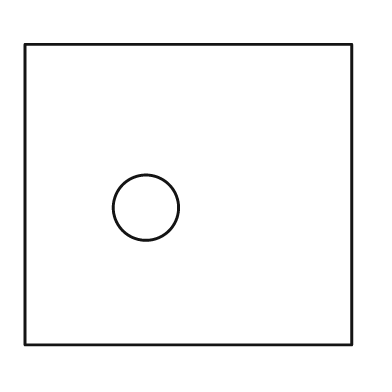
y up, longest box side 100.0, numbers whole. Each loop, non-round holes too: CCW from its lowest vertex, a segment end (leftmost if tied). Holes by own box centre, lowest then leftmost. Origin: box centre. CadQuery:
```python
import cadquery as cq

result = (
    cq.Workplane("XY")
    .moveTo(-50.0, -46.0)
    .lineTo(50.0, -46.0)
    .lineTo(50.0, 46.0)
    .lineTo(-50.0, 46.0)
    .close()
    .moveTo(-13.0, -4.0)
    .circle(10.0)
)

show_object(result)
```